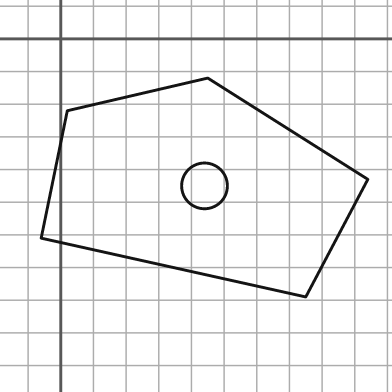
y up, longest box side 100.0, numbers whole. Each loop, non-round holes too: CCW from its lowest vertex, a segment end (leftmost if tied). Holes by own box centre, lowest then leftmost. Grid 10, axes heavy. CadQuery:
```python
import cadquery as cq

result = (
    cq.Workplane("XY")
    .moveTo(75.0, -79.0)
    .lineTo(94.0, -43.0)
    .lineTo(45.0, -12.0)
    .lineTo(2.0, -22.0)
    .lineTo(-6.0, -61.0)
    .close()
    .moveTo(44.0, -45.0)
    .circle(7.0)
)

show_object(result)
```